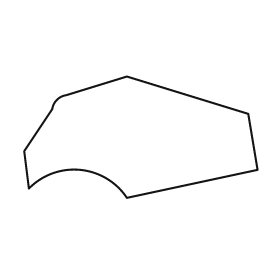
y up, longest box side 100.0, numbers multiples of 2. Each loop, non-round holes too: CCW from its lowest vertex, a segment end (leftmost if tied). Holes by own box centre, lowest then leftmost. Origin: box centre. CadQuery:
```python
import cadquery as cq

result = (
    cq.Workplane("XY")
    .moveTo(-6.0, -26.0)
    .lineTo(50.0, -14.0)
    .lineTo(46.0, 10.0)
    .lineTo(-6.0, 26.0)
    .lineTo(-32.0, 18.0)
    .threePointArc((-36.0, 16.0), (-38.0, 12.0))
    .lineTo(-50.0, -6.0)
    .lineTo(-48.0, -22.0)
    .threePointArc((-26.0, -14.0), (-6.0, -26.0))
    .close()
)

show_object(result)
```